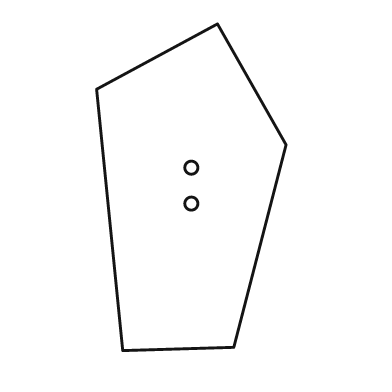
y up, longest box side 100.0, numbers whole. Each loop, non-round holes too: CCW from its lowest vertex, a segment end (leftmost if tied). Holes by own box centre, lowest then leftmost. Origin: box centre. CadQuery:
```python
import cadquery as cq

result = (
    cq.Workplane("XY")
    .moveTo(-21.0, -50.0)
    .lineTo(13.0, -49.0)
    .lineTo(29.0, 13.0)
    .lineTo(8.0, 50.0)
    .lineTo(-29.0, 30.0)
    .close()
    .moveTo(0.0, -5.0)
    .circle(2.0)
    .moveTo(0.0, 6.0)
    .circle(2.0)
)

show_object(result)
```